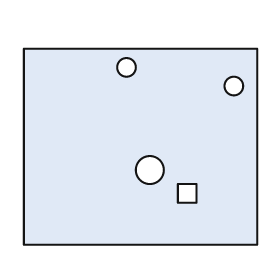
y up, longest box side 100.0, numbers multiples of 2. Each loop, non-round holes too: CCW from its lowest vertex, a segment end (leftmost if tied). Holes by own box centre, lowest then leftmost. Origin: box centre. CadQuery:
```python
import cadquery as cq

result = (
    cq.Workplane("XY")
    .moveTo(-50.0, -42.0)
    .lineTo(50.0, -42.0)
    .lineTo(50.0, 42.0)
    .lineTo(-50.0, 42.0)
    .close()
    .moveTo(16.0, -24.0)
    .lineTo(24.0, -24.0)
    .lineTo(24.0, -16.0)
    .lineTo(16.0, -16.0)
    .close()
    .moveTo(4.0, -10.0)
    .circle(6.0)
    .moveTo(40.0, 26.0)
    .circle(4.0)
    .moveTo(-6.0, 34.0)
    .circle(4.0)
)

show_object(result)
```